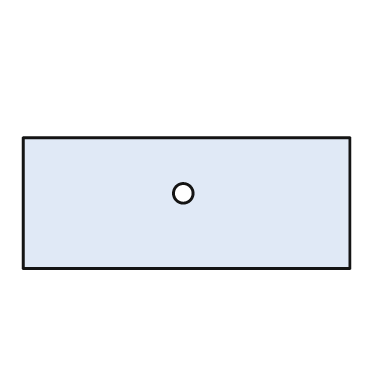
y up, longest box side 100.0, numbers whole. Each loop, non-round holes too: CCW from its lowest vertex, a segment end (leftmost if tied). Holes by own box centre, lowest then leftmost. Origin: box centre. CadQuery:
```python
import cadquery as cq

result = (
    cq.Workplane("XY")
    .moveTo(-50.0, -20.0)
    .lineTo(50.0, -20.0)
    .lineTo(50.0, 20.0)
    .lineTo(-50.0, 20.0)
    .close()
    .moveTo(-1.0, 3.0)
    .circle(3.0)
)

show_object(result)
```